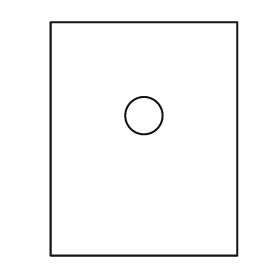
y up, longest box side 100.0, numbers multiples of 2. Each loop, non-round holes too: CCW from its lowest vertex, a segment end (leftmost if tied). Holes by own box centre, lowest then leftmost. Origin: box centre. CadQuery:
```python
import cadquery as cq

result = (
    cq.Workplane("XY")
    .moveTo(-40.0, -50.0)
    .lineTo(40.0, -50.0)
    .lineTo(40.0, 50.0)
    .lineTo(-40.0, 50.0)
    .close()
    .moveTo(0.0, 10.0)
    .circle(8.0)
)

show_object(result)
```